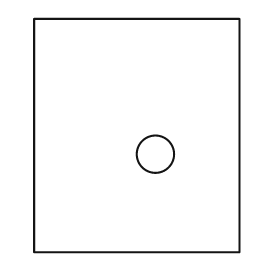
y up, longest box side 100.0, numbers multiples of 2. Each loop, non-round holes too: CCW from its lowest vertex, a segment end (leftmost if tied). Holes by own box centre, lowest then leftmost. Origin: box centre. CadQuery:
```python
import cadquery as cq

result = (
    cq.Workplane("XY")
    .moveTo(-44.0, -50.0)
    .lineTo(44.0, -50.0)
    .lineTo(44.0, 50.0)
    .lineTo(-44.0, 50.0)
    .close()
    .moveTo(8.0, -8.0)
    .circle(8.0)
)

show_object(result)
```